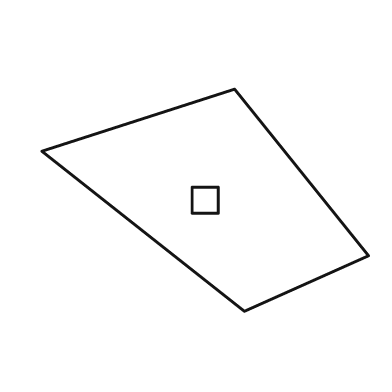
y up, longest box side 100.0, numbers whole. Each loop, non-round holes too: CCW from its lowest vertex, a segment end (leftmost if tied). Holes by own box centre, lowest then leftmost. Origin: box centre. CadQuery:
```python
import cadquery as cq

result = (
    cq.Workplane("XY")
    .moveTo(12.0, -34.0)
    .lineTo(50.0, -17.0)
    .lineTo(9.0, 34.0)
    .lineTo(-50.0, 15.0)
    .close()
    .moveTo(-4.0, -4.0)
    .lineTo(4.0, -4.0)
    .lineTo(4.0, 4.0)
    .lineTo(-4.0, 4.0)
    .close()
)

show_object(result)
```